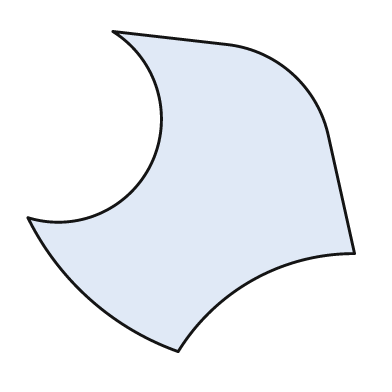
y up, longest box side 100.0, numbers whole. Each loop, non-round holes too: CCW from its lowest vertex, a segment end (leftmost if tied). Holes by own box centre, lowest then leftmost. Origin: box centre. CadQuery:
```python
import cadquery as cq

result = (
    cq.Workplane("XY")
    .moveTo(-4.0, -49.0)
    .threePointArc((19.0, -27.0), (50.0, -19.0))
    .lineTo(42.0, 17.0)
    .threePointArc((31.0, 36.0), (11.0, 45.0))
    .lineTo(-24.0, 49.0)
    .threePointArc((-12.0, 9.0), (-50.0, -8.0))
    .threePointArc((-31.0, -33.0), (-4.0, -49.0))
    .close()
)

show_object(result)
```